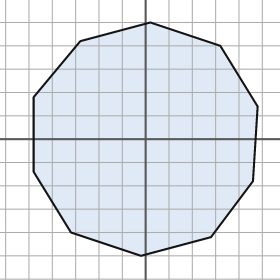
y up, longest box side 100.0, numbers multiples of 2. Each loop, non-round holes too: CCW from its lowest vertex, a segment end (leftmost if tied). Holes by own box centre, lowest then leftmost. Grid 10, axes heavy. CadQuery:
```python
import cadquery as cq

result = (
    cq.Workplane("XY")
    .moveTo(-2.0, -50.0)
    .lineTo(28.0, -42.0)
    .lineTo(46.0, -18.0)
    .lineTo(48.0, 14.0)
    .lineTo(32.0, 40.0)
    .lineTo(2.0, 50.0)
    .lineTo(-28.0, 42.0)
    .lineTo(-48.0, 18.0)
    .lineTo(-48.0, -14.0)
    .lineTo(-32.0, -40.0)
    .close()
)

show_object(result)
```